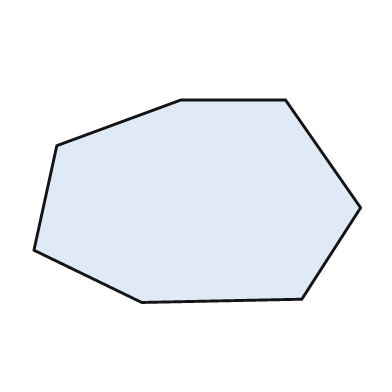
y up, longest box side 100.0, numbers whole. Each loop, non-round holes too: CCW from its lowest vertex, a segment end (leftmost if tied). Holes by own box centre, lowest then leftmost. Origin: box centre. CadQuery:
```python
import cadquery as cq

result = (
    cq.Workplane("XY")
    .moveTo(-17.0, -31.0)
    .lineTo(32.0, -30.0)
    .lineTo(50.0, -2.0)
    .lineTo(27.0, 31.0)
    .lineTo(-5.0, 31.0)
    .lineTo(-43.0, 17.0)
    .lineTo(-50.0, -15.0)
    .close()
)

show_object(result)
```